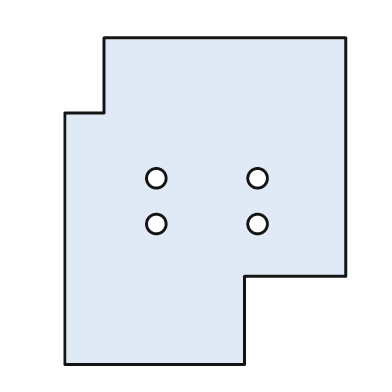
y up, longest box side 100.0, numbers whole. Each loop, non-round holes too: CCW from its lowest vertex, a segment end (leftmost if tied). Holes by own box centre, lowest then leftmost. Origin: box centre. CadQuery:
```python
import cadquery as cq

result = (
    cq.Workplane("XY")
    .moveTo(-43.0, -50.0)
    .lineTo(12.0, -50.0)
    .lineTo(12.0, -23.0)
    .lineTo(43.0, -23.0)
    .lineTo(43.0, 50.0)
    .lineTo(-31.0, 50.0)
    .lineTo(-31.0, 27.0)
    .lineTo(-43.0, 27.0)
    .close()
    .moveTo(-15.0, -7.0)
    .circle(3.0)
    .moveTo(16.0, -7.0)
    .circle(3.0)
    .moveTo(-15.0, 7.0)
    .circle(3.0)
    .moveTo(16.0, 7.0)
    .circle(3.0)
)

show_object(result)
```